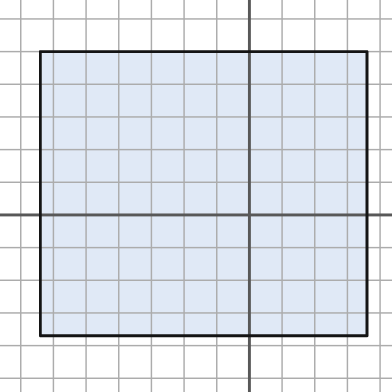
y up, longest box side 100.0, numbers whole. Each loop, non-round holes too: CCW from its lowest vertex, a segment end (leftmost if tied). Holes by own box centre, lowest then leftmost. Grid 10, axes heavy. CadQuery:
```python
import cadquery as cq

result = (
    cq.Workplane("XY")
    .moveTo(-64.0, -37.0)
    .lineTo(36.0, -37.0)
    .lineTo(36.0, 50.0)
    .lineTo(-64.0, 50.0)
    .close()
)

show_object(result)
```